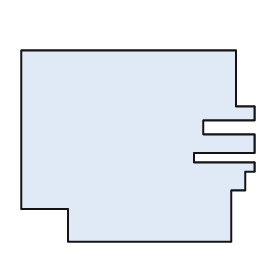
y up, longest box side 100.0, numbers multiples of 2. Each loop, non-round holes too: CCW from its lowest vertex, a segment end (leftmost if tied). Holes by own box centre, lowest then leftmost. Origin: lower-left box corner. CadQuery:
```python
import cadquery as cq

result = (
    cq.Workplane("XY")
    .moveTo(20.0, 0.0)
    .lineTo(90.0, 0.0)
    .lineTo(90.0, 22.0)
    .lineTo(96.0, 22.0)
    .lineTo(96.0, 30.0)
    .lineTo(100.0, 30.0)
    .lineTo(100.0, 34.0)
    .lineTo(74.0, 34.0)
    .lineTo(74.0, 38.0)
    .lineTo(100.0, 38.0)
    .lineTo(100.0, 46.0)
    .lineTo(78.0, 46.0)
    .lineTo(78.0, 52.0)
    .lineTo(100.0, 52.0)
    .lineTo(100.0, 58.0)
    .lineTo(92.0, 58.0)
    .lineTo(92.0, 82.0)
    .lineTo(0.0, 82.0)
    .lineTo(0.0, 14.0)
    .lineTo(20.0, 14.0)
    .close()
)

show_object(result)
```